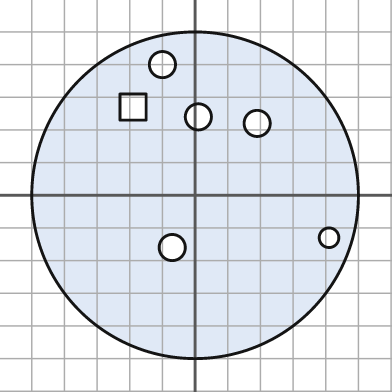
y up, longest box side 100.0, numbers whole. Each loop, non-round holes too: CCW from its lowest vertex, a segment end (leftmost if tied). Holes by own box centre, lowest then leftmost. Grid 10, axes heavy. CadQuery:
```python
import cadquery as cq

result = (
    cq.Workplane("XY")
    .moveTo(0.0, 0.0)
    .circle(50.0)
    .moveTo(-7.0, -16.0)
    .circle(4.0)
    .moveTo(41.0, -13.0)
    .circle(3.0)
    .moveTo(19.0, 22.0)
    .circle(4.0)
    .moveTo(1.0, 24.0)
    .circle(4.0)
    .moveTo(-23.0, 23.0)
    .lineTo(-15.0, 23.0)
    .lineTo(-15.0, 31.0)
    .lineTo(-23.0, 31.0)
    .close()
    .moveTo(-10.0, 40.0)
    .circle(4.0)
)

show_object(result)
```